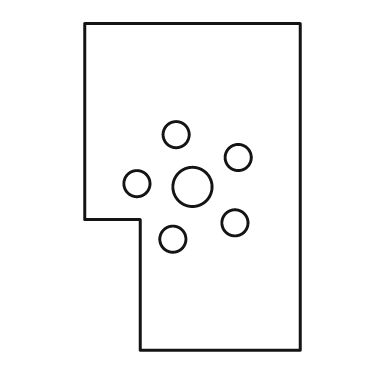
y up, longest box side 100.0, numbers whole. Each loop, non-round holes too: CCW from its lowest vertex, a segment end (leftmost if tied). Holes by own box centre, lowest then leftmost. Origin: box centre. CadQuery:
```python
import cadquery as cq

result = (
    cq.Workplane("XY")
    .moveTo(-16.0, -50.0)
    .lineTo(33.0, -50.0)
    .lineTo(33.0, 50.0)
    .lineTo(-33.0, 50.0)
    .lineTo(-33.0, -10.0)
    .lineTo(-16.0, -10.0)
    .close()
    .moveTo(-6.0, -16.0)
    .circle(4.0)
    .moveTo(13.0, -11.0)
    .circle(4.0)
    .moveTo(0.0, 0.0)
    .circle(6.0)
    .moveTo(-17.0, 1.0)
    .circle(4.0)
    .moveTo(14.0, 9.0)
    .circle(4.0)
    .moveTo(-5.0, 16.0)
    .circle(4.0)
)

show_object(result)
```